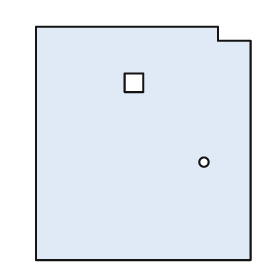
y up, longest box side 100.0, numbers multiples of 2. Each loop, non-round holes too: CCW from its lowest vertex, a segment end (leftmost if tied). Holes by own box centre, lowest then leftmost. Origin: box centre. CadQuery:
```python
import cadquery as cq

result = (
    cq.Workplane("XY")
    .moveTo(-46.0, -50.0)
    .lineTo(46.0, -50.0)
    .lineTo(46.0, 44.0)
    .lineTo(32.0, 44.0)
    .lineTo(32.0, 50.0)
    .lineTo(-46.0, 50.0)
    .close()
    .moveTo(26.0, -8.0)
    .circle(2.0)
    .moveTo(-8.0, 22.0)
    .lineTo(0.0, 22.0)
    .lineTo(0.0, 30.0)
    .lineTo(-8.0, 30.0)
    .close()
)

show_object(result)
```